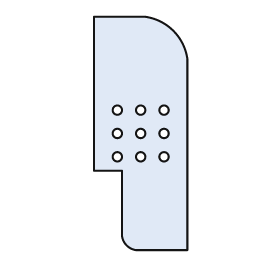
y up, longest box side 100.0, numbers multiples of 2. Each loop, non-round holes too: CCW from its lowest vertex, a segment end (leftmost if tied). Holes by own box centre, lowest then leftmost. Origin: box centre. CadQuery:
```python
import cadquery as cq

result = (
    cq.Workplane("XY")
    .moveTo(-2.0, -50.0)
    .lineTo(20.0, -50.0)
    .lineTo(20.0, 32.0)
    .threePointArc((14.0, 44.0), (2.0, 50.0))
    .lineTo(-20.0, 50.0)
    .lineTo(-20.0, -16.0)
    .lineTo(-8.0, -16.0)
    .lineTo(-8.0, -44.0)
    .threePointArc((-6.0, -48.0), (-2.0, -50.0))
    .close()
    .moveTo(-10.0, -10.0)
    .circle(2.0)
    .moveTo(0.0, -10.0)
    .circle(2.0)
    .moveTo(10.0, -10.0)
    .circle(2.0)
    .moveTo(-10.0, 0.0)
    .circle(2.0)
    .moveTo(0.0, 0.0)
    .circle(2.0)
    .moveTo(10.0, 0.0)
    .circle(2.0)
    .moveTo(-10.0, 10.0)
    .circle(2.0)
    .moveTo(0.0, 10.0)
    .circle(2.0)
    .moveTo(10.0, 10.0)
    .circle(2.0)
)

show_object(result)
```